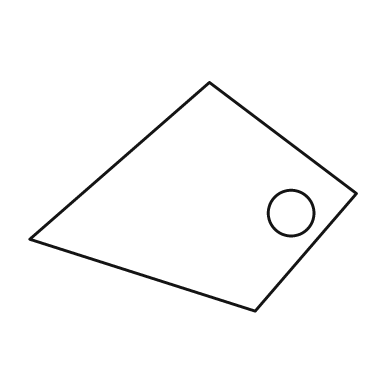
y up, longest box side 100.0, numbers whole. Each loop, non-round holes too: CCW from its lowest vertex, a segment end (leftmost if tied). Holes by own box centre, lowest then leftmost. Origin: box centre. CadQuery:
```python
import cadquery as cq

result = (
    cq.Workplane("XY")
    .moveTo(19.0, -35.0)
    .lineTo(50.0, 1.0)
    .lineTo(5.0, 35.0)
    .lineTo(-50.0, -13.0)
    .close()
    .moveTo(30.0, -5.0)
    .circle(7.0)
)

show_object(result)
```